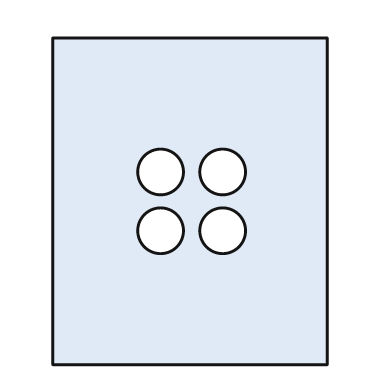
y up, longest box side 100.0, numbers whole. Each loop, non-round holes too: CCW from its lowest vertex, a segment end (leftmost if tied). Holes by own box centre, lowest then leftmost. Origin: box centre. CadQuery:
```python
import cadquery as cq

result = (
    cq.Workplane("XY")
    .moveTo(-42.0, -50.0)
    .lineTo(42.0, -50.0)
    .lineTo(42.0, 50.0)
    .lineTo(-42.0, 50.0)
    .close()
    .moveTo(-9.0, -9.0)
    .circle(7.0)
    .moveTo(10.0, -9.0)
    .circle(7.0)
    .moveTo(-9.0, 9.0)
    .circle(7.0)
    .moveTo(10.0, 9.0)
    .circle(7.0)
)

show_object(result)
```